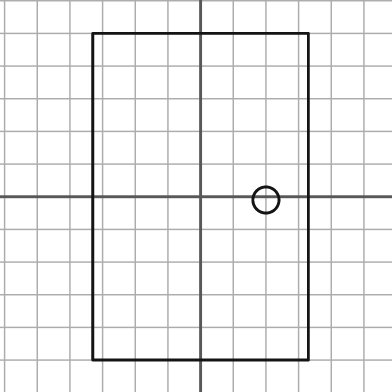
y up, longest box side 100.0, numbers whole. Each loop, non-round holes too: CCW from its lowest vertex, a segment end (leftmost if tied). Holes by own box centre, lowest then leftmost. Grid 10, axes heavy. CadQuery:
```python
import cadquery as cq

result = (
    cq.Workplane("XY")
    .moveTo(-33.0, -50.0)
    .lineTo(33.0, -50.0)
    .lineTo(33.0, 50.0)
    .lineTo(-33.0, 50.0)
    .close()
    .moveTo(20.0, -1.0)
    .circle(4.0)
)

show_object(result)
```